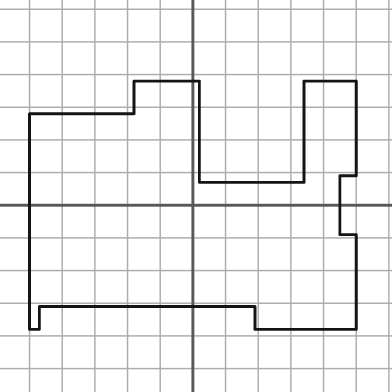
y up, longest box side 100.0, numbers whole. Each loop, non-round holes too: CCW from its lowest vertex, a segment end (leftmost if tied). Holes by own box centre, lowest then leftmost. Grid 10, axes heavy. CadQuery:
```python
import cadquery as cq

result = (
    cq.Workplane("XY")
    .moveTo(-50.0, -38.0)
    .lineTo(-47.0, -38.0)
    .lineTo(-47.0, -31.0)
    .lineTo(19.0, -31.0)
    .lineTo(19.0, -38.0)
    .lineTo(50.0, -38.0)
    .lineTo(50.0, -9.0)
    .lineTo(45.0, -9.0)
    .lineTo(45.0, 9.0)
    .lineTo(50.0, 9.0)
    .lineTo(50.0, 38.0)
    .lineTo(34.0, 38.0)
    .lineTo(34.0, 7.0)
    .lineTo(2.0, 7.0)
    .lineTo(2.0, 38.0)
    .lineTo(-18.0, 38.0)
    .lineTo(-18.0, 28.0)
    .lineTo(-50.0, 28.0)
    .close()
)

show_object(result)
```